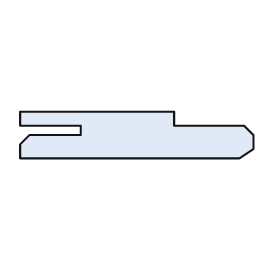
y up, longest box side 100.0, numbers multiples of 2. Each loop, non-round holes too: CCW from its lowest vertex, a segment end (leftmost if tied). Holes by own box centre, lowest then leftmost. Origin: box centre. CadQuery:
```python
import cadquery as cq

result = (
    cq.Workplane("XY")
    .moveTo(-50.0, -10.0)
    .lineTo(44.0, -10.0)
    .lineTo(50.0, -6.0)
    .lineTo(50.0, 0.0)
    .lineTo(46.0, 4.0)
    .lineTo(16.0, 4.0)
    .lineTo(16.0, 10.0)
    .lineTo(-50.0, 10.0)
    .lineTo(-50.0, 4.0)
    .lineTo(-24.0, 4.0)
    .lineTo(-24.0, 0.0)
    .lineTo(-46.0, 0.0)
    .lineTo(-50.0, -4.0)
    .close()
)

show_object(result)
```